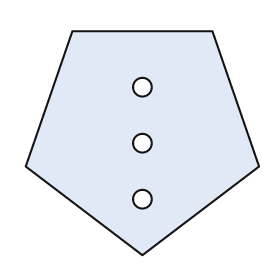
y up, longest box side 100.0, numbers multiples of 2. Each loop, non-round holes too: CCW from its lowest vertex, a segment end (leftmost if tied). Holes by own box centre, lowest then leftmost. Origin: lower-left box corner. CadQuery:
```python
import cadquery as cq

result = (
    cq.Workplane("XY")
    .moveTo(50.0, 0.0)
    .lineTo(100.0, 38.0)
    .lineTo(80.0, 96.0)
    .lineTo(20.0, 96.0)
    .lineTo(0.0, 38.0)
    .close()
    .moveTo(50.0, 24.0)
    .circle(4.0)
    .moveTo(50.0, 48.0)
    .circle(4.0)
    .moveTo(50.0, 72.0)
    .circle(4.0)
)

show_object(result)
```